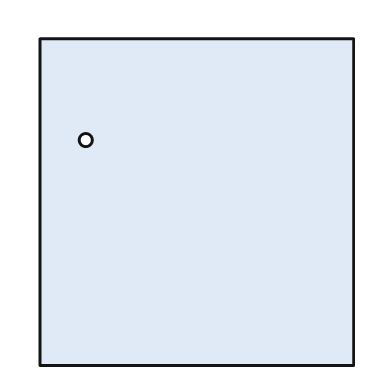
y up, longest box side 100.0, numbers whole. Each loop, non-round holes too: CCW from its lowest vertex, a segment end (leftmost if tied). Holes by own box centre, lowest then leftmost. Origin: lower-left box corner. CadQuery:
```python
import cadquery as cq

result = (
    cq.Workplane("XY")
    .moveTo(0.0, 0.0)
    .lineTo(96.0, 0.0)
    .lineTo(96.0, 100.0)
    .lineTo(0.0, 100.0)
    .close()
    .moveTo(14.0, 69.0)
    .circle(2.0)
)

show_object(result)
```